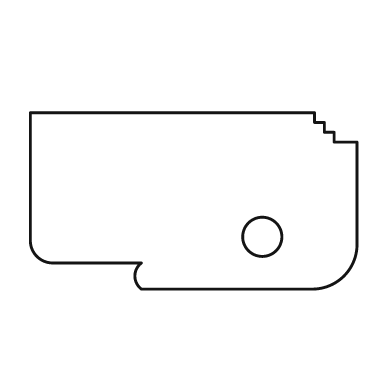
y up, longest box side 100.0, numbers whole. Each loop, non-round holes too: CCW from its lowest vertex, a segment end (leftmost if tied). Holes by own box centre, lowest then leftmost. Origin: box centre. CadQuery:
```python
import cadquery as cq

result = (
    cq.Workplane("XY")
    .moveTo(-16.0, -27.0)
    .lineTo(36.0, -27.0)
    .threePointArc((46.0, -23.0), (50.0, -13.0))
    .lineTo(50.0, 18.0)
    .lineTo(43.0, 18.0)
    .lineTo(43.0, 21.0)
    .lineTo(40.0, 21.0)
    .lineTo(40.0, 24.0)
    .lineTo(37.0, 24.0)
    .lineTo(37.0, 27.0)
    .lineTo(-50.0, 27.0)
    .lineTo(-50.0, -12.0)
    .threePointArc((-48.0, -17.0), (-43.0, -19.0))
    .lineTo(-16.0, -19.0)
    .threePointArc((-18.0, -23.0), (-16.0, -27.0))
    .close()
    .moveTo(21.0, -11.0)
    .circle(6.0)
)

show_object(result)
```